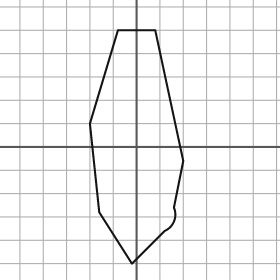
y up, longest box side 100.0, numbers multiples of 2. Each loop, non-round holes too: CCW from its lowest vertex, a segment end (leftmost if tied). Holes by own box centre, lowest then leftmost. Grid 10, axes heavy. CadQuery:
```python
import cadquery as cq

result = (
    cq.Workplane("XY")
    .moveTo(-2.0, -50.0)
    .lineTo(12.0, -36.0)
    .threePointArc((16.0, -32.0), (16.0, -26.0))
    .lineTo(20.0, -6.0)
    .lineTo(8.0, 50.0)
    .lineTo(-8.0, 50.0)
    .lineTo(-20.0, 10.0)
    .lineTo(-16.0, -28.0)
    .close()
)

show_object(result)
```